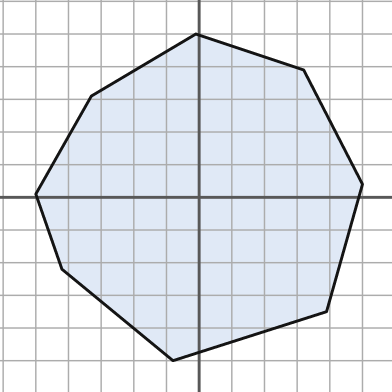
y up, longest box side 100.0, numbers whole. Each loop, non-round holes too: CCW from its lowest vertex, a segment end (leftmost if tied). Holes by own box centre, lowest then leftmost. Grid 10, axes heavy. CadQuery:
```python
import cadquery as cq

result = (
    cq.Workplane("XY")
    .moveTo(-8.0, -50.0)
    .lineTo(39.0, -35.0)
    .lineTo(50.0, 4.0)
    .lineTo(32.0, 39.0)
    .lineTo(-1.0, 50.0)
    .lineTo(-33.0, 31.0)
    .lineTo(-50.0, 1.0)
    .lineTo(-42.0, -22.0)
    .close()
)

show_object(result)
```